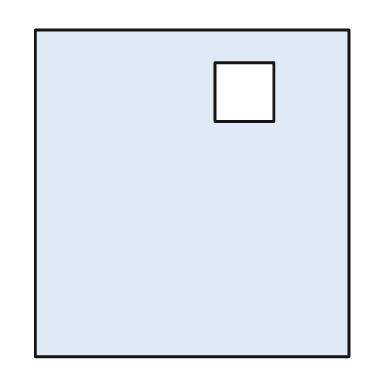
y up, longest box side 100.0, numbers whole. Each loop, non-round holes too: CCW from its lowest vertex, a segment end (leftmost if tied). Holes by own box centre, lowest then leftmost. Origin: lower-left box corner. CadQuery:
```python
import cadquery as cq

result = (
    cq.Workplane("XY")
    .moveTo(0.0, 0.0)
    .lineTo(96.0, 0.0)
    .lineTo(96.0, 100.0)
    .lineTo(0.0, 100.0)
    .close()
    .moveTo(55.0, 72.0)
    .lineTo(73.0, 72.0)
    .lineTo(73.0, 90.0)
    .lineTo(55.0, 90.0)
    .close()
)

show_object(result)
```